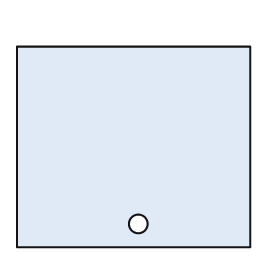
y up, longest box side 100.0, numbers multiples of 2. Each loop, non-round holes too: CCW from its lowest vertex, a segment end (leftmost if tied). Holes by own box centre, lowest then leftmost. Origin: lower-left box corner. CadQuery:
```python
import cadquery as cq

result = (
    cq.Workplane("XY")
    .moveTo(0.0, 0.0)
    .lineTo(100.0, 0.0)
    .lineTo(100.0, 86.0)
    .lineTo(0.0, 86.0)
    .close()
    .moveTo(52.0, 10.0)
    .circle(4.0)
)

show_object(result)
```